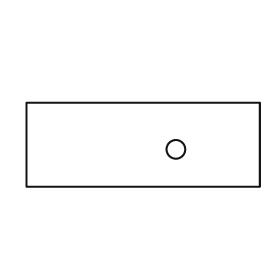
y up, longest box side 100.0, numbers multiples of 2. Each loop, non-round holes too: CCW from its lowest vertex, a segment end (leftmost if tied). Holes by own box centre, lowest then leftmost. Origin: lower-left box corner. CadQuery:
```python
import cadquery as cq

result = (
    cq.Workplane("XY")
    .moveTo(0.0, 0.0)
    .lineTo(100.0, 0.0)
    .lineTo(100.0, 36.0)
    .lineTo(0.0, 36.0)
    .close()
    .moveTo(64.0, 16.0)
    .circle(4.0)
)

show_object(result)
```